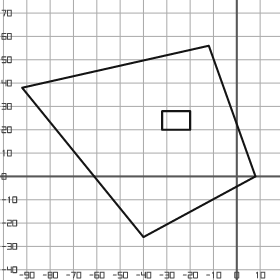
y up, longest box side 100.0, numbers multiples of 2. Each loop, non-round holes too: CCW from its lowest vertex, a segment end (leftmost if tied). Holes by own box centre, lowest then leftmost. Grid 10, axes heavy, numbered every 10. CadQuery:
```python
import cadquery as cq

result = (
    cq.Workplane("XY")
    .moveTo(-40.0, -26.0)
    .lineTo(8.0, 0.0)
    .lineTo(-12.0, 56.0)
    .lineTo(-92.0, 38.0)
    .close()
    .moveTo(-32.0, 20.0)
    .lineTo(-20.0, 20.0)
    .lineTo(-20.0, 28.0)
    .lineTo(-32.0, 28.0)
    .close()
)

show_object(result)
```